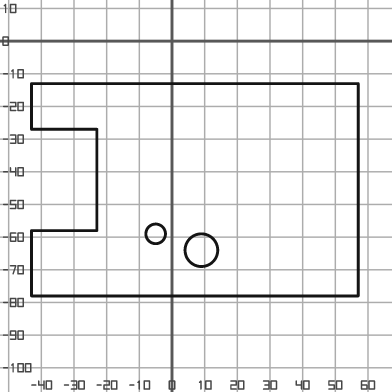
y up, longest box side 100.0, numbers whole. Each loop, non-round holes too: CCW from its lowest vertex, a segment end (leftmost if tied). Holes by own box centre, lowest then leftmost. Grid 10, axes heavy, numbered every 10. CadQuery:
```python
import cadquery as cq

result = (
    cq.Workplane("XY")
    .moveTo(-43.0, -78.0)
    .lineTo(57.0, -78.0)
    .lineTo(57.0, -13.0)
    .lineTo(-43.0, -13.0)
    .lineTo(-43.0, -27.0)
    .lineTo(-23.0, -27.0)
    .lineTo(-23.0, -58.0)
    .lineTo(-43.0, -58.0)
    .close()
    .moveTo(9.0, -64.0)
    .circle(5.0)
    .moveTo(-5.0, -59.0)
    .circle(3.0)
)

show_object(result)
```